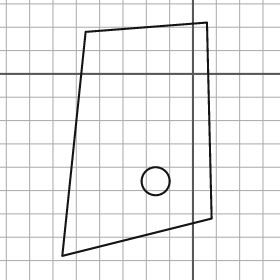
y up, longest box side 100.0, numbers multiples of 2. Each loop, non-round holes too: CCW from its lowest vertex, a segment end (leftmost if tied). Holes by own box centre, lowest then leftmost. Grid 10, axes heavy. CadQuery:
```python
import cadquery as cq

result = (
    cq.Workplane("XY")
    .moveTo(-56.0, -78.0)
    .lineTo(8.0, -62.0)
    .lineTo(6.0, 22.0)
    .lineTo(-46.0, 18.0)
    .close()
    .moveTo(-16.0, -46.0)
    .circle(6.0)
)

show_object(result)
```